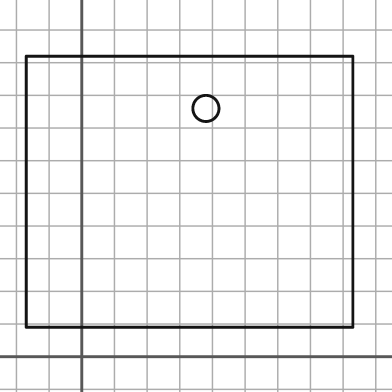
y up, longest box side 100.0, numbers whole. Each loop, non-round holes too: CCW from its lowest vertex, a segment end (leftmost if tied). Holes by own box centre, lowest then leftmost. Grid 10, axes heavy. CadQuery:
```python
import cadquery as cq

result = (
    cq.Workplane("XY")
    .moveTo(-17.0, 9.0)
    .lineTo(83.0, 9.0)
    .lineTo(83.0, 92.0)
    .lineTo(-17.0, 92.0)
    .close()
    .moveTo(38.0, 76.0)
    .circle(4.0)
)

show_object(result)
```